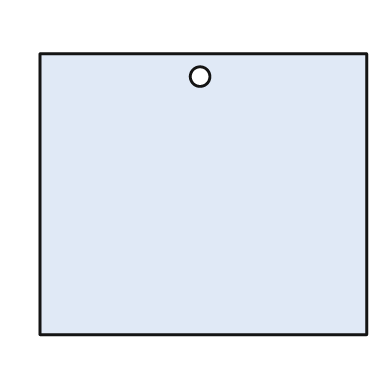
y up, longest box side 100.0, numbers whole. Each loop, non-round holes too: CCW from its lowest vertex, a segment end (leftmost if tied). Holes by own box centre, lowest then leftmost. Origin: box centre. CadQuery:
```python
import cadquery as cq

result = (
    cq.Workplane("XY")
    .moveTo(-50.0, -43.0)
    .lineTo(50.0, -43.0)
    .lineTo(50.0, 43.0)
    .lineTo(-50.0, 43.0)
    .close()
    .moveTo(-1.0, 36.0)
    .circle(3.0)
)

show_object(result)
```